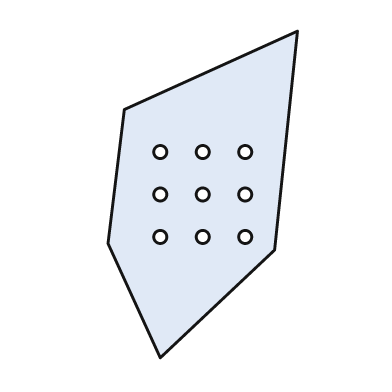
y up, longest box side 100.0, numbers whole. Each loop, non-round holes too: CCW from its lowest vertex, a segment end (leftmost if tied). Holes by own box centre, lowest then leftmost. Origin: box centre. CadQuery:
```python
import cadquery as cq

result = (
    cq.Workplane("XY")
    .moveTo(-13.0, -50.0)
    .lineTo(22.0, -17.0)
    .lineTo(29.0, 50.0)
    .lineTo(-24.0, 26.0)
    .lineTo(-29.0, -15.0)
    .close()
    .moveTo(-13.0, -13.0)
    .circle(2.0)
    .moveTo(0.0, -13.0)
    .circle(2.0)
    .moveTo(13.0, -13.0)
    .circle(2.0)
    .moveTo(-13.0, 0.0)
    .circle(2.0)
    .moveTo(0.0, 0.0)
    .circle(2.0)
    .moveTo(13.0, 0.0)
    .circle(2.0)
    .moveTo(-13.0, 13.0)
    .circle(2.0)
    .moveTo(0.0, 13.0)
    .circle(2.0)
    .moveTo(13.0, 13.0)
    .circle(2.0)
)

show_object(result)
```